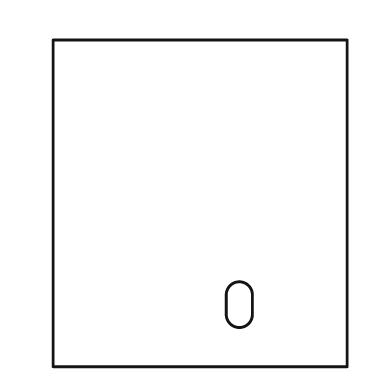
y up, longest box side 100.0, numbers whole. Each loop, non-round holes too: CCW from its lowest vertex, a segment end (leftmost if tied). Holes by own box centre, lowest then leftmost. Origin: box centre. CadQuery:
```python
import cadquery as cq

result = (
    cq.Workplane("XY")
    .moveTo(-45.0, -50.0)
    .lineTo(45.0, -50.0)
    .lineTo(45.0, 50.0)
    .lineTo(-45.0, 50.0)
    .close()
    .moveTo(8.0, -34.0)
    .threePointArc((12.0, -38.0), (16.0, -34.0))
    .lineTo(16.0, -28.0)
    .threePointArc((12.0, -24.0), (8.0, -28.0))
    .close()
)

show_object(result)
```